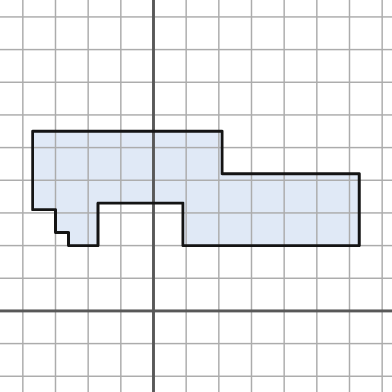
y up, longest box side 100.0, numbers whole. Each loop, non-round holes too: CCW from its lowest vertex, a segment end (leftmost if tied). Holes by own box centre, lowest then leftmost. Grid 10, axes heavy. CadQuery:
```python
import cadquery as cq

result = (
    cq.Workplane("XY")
    .moveTo(-26.0, 20.0)
    .lineTo(-17.0, 20.0)
    .lineTo(-17.0, 33.0)
    .lineTo(9.0, 33.0)
    .lineTo(9.0, 20.0)
    .lineTo(63.0, 20.0)
    .lineTo(63.0, 42.0)
    .lineTo(21.0, 42.0)
    .lineTo(21.0, 55.0)
    .lineTo(-37.0, 55.0)
    .lineTo(-37.0, 31.0)
    .lineTo(-30.0, 31.0)
    .lineTo(-30.0, 24.0)
    .lineTo(-26.0, 24.0)
    .close()
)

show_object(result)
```